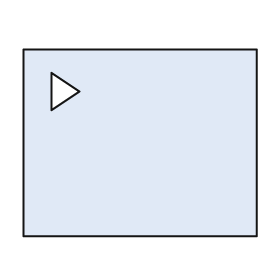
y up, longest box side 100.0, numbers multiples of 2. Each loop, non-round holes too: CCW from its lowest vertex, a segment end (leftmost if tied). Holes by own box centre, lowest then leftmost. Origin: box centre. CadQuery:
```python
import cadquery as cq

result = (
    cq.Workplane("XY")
    .moveTo(-50.0, -40.0)
    .lineTo(50.0, -40.0)
    .lineTo(50.0, 40.0)
    .lineTo(-50.0, 40.0)
    .close()
    .moveTo(-38.0, 14.0)
    .lineTo(-26.0, 22.0)
    .lineTo(-38.0, 30.0)
    .close()
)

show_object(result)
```